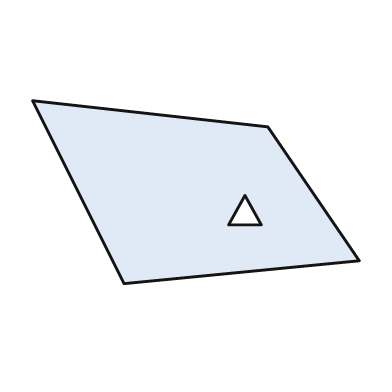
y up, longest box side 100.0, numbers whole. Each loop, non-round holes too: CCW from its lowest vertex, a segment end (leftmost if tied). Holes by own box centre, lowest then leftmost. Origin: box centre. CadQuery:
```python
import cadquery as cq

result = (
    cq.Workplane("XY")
    .moveTo(-22.0, -28.0)
    .lineTo(50.0, -21.0)
    .lineTo(22.0, 20.0)
    .lineTo(-50.0, 28.0)
    .close()
    .moveTo(10.0, -10.0)
    .lineTo(20.0, -10.0)
    .lineTo(15.0, -1.0)
    .close()
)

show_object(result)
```